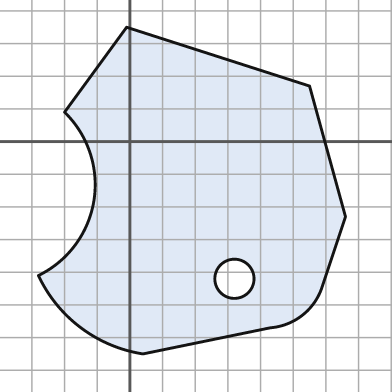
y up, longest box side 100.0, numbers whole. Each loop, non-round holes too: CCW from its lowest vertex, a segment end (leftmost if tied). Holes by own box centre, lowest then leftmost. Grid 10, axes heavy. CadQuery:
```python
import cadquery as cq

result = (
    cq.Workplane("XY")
    .moveTo(4.0, -65.0)
    .lineTo(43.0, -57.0)
    .threePointArc((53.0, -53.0), (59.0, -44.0))
    .lineTo(66.0, -23.0)
    .lineTo(55.0, 17.0)
    .lineTo(-1.0, 35.0)
    .lineTo(-20.0, 9.0)
    .threePointArc((-11.0, -18.0), (-28.0, -41.0))
    .threePointArc((-15.0, -57.0), (4.0, -65.0))
    .close()
    .moveTo(32.0, -42.0)
    .circle(6.0)
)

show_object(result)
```